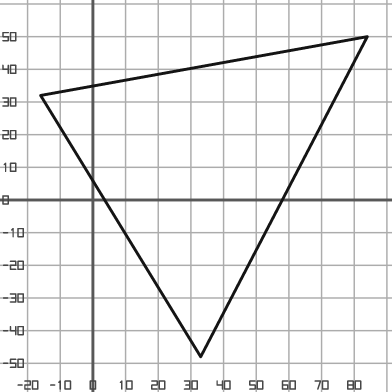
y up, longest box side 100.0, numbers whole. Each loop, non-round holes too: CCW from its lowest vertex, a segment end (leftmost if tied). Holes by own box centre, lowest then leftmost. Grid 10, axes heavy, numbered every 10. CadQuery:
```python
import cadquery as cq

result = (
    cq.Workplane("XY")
    .moveTo(33.0, -48.0)
    .lineTo(84.0, 50.0)
    .lineTo(-16.0, 32.0)
    .close()
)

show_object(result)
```